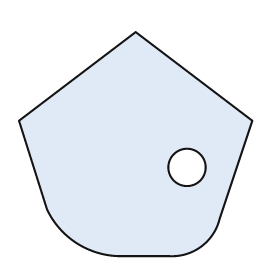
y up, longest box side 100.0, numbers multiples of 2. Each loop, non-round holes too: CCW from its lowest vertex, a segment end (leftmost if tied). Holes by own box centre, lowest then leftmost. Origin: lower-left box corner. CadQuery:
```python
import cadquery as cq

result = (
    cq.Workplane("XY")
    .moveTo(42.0, 0.0)
    .lineTo(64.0, 0.0)
    .threePointArc((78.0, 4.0), (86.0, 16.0))
    .lineTo(100.0, 58.0)
    .lineTo(50.0, 96.0)
    .lineTo(0.0, 58.0)
    .lineTo(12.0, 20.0)
    .threePointArc((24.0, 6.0), (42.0, 0.0))
    .close()
    .moveTo(72.0, 38.0)
    .circle(8.0)
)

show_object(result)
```